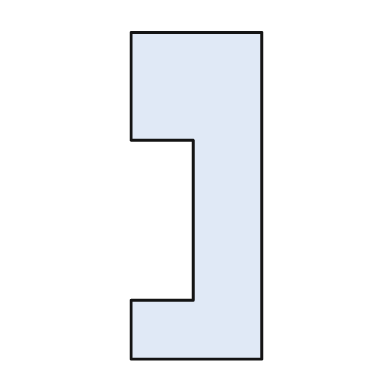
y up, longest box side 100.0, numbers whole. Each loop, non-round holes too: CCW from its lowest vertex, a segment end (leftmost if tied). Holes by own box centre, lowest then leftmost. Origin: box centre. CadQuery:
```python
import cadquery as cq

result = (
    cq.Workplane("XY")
    .moveTo(-20.0, -50.0)
    .lineTo(20.0, -50.0)
    .lineTo(20.0, 50.0)
    .lineTo(-20.0, 50.0)
    .lineTo(-20.0, 17.0)
    .lineTo(-1.0, 17.0)
    .lineTo(-1.0, -32.0)
    .lineTo(-20.0, -32.0)
    .close()
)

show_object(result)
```